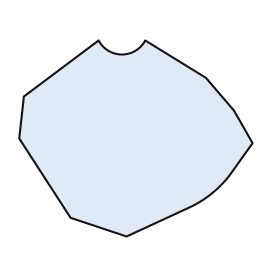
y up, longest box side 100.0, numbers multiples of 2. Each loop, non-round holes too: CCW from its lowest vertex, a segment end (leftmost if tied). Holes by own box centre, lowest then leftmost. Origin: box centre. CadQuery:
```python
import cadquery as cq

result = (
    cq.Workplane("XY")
    .moveTo(-4.0, -42.0)
    .lineTo(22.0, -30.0)
    .threePointArc((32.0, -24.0), (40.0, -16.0))
    .lineTo(50.0, -2.0)
    .lineTo(42.0, 12.0)
    .lineTo(30.0, 26.0)
    .lineTo(4.0, 42.0)
    .threePointArc((-6.0, 36.0), (-16.0, 42.0))
    .lineTo(-48.0, 18.0)
    .lineTo(-50.0, 0.0)
    .lineTo(-28.0, -34.0)
    .close()
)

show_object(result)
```